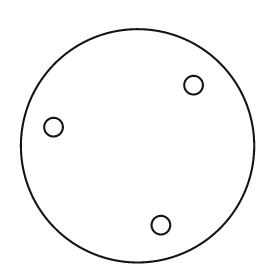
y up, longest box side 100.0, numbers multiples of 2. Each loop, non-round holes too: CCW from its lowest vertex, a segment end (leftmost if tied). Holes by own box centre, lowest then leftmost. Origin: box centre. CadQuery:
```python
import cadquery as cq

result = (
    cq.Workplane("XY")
    .moveTo(0.0, 0.0)
    .circle(50.0)
    .moveTo(10.0, -34.0)
    .circle(4.0)
    .moveTo(-36.0, 8.0)
    .circle(4.0)
    .moveTo(24.0, 26.0)
    .circle(4.0)
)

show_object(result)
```